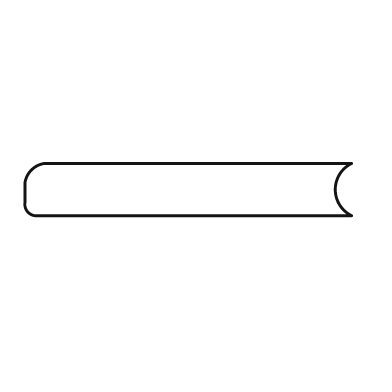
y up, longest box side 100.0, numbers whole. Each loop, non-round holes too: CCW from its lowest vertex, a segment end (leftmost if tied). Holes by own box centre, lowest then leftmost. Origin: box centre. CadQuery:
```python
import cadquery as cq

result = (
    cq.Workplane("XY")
    .moveTo(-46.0, -8.0)
    .lineTo(50.0, -8.0)
    .threePointArc((45.0, 0.0), (50.0, 8.0))
    .lineTo(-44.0, 8.0)
    .threePointArc((-48.0, 6.0), (-50.0, 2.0))
    .lineTo(-50.0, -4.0)
    .threePointArc((-49.0, -7.0), (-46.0, -8.0))
    .close()
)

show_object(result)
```